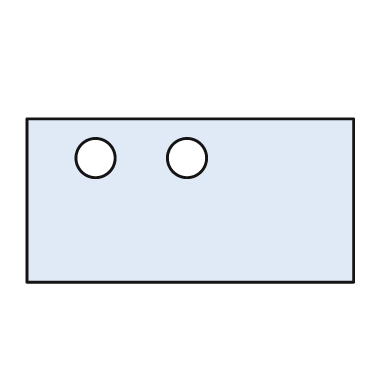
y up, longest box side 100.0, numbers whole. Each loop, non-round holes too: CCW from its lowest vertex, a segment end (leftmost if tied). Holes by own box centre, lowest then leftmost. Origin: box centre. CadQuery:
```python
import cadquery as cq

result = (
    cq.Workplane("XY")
    .moveTo(-50.0, -25.0)
    .lineTo(50.0, -25.0)
    .lineTo(50.0, 25.0)
    .lineTo(-50.0, 25.0)
    .close()
    .moveTo(-29.0, 13.0)
    .circle(6.0)
    .moveTo(-1.0, 13.0)
    .circle(6.0)
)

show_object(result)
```